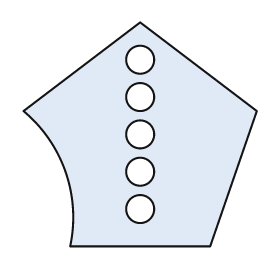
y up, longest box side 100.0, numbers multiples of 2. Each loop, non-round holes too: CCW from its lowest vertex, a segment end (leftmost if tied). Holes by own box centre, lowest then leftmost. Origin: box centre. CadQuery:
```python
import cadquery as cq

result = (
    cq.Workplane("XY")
    .moveTo(-30.0, -48.0)
    .lineTo(30.0, -48.0)
    .lineTo(50.0, 10.0)
    .lineTo(0.0, 48.0)
    .lineTo(-50.0, 10.0)
    .threePointArc((-32.0, -16.0), (-30.0, -48.0))
    .close()
    .moveTo(0.0, -32.0)
    .circle(6.0)
    .moveTo(0.0, -16.0)
    .circle(6.0)
    .moveTo(0.0, 0.0)
    .circle(6.0)
    .moveTo(0.0, 16.0)
    .circle(6.0)
    .moveTo(0.0, 32.0)
    .circle(6.0)
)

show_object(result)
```